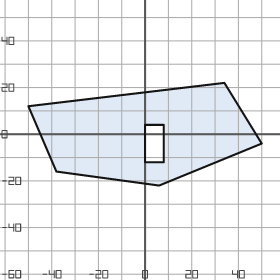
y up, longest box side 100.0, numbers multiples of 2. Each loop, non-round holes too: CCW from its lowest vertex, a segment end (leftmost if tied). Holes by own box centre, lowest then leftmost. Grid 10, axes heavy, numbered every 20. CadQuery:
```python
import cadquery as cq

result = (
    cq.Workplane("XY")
    .moveTo(6.0, -22.0)
    .lineTo(50.0, -4.0)
    .lineTo(34.0, 22.0)
    .lineTo(-50.0, 12.0)
    .lineTo(-38.0, -16.0)
    .close()
    .moveTo(0.0, -12.0)
    .lineTo(8.0, -12.0)
    .lineTo(8.0, 4.0)
    .lineTo(0.0, 4.0)
    .close()
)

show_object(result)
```